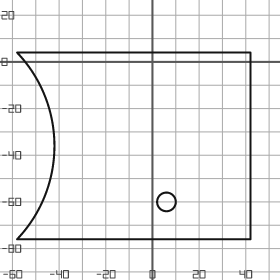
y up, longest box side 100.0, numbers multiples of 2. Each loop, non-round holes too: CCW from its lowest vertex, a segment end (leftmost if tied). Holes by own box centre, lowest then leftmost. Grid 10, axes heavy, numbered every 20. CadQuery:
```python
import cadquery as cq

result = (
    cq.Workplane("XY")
    .moveTo(-58.0, -76.0)
    .lineTo(42.0, -76.0)
    .lineTo(42.0, 4.0)
    .lineTo(-58.0, 4.0)
    .threePointArc((-42.0, -36.0), (-58.0, -76.0))
    .close()
    .moveTo(6.0, -60.0)
    .circle(4.0)
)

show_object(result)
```